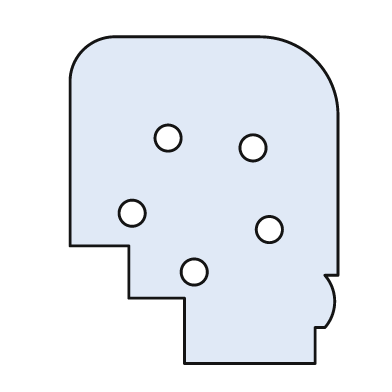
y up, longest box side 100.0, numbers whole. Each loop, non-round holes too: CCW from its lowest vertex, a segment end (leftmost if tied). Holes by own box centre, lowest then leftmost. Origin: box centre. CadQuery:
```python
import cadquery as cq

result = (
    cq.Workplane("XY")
    .moveTo(-6.0, -50.0)
    .lineTo(34.0, -50.0)
    .lineTo(34.0, -39.0)
    .lineTo(37.0, -39.0)
    .threePointArc((40.0, -31.0), (37.0, -23.0))
    .lineTo(41.0, -23.0)
    .lineTo(41.0, 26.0)
    .threePointArc((34.0, 43.0), (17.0, 50.0))
    .lineTo(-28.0, 50.0)
    .threePointArc((-37.0, 46.0), (-41.0, 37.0))
    .lineTo(-41.0, -14.0)
    .lineTo(-23.0, -14.0)
    .lineTo(-23.0, -30.0)
    .lineTo(-6.0, -30.0)
    .close()
    .moveTo(-3.0, -22.0)
    .circle(4.0)
    .moveTo(20.0, -9.0)
    .circle(4.0)
    .moveTo(-22.0, -4.0)
    .circle(4.0)
    .moveTo(15.0, 16.0)
    .circle(4.0)
    .moveTo(-11.0, 19.0)
    .circle(4.0)
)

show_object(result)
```